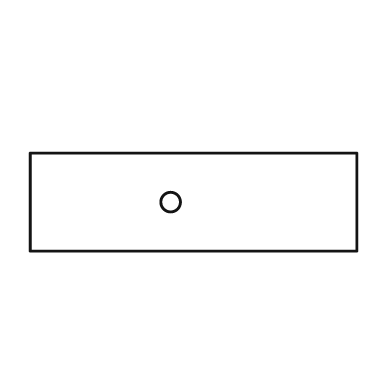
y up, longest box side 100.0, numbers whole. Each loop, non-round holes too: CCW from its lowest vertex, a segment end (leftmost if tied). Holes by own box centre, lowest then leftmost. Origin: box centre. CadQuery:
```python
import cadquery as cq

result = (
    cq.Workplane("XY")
    .moveTo(-50.0, -15.0)
    .lineTo(50.0, -15.0)
    .lineTo(50.0, 15.0)
    .lineTo(-50.0, 15.0)
    .close()
    .moveTo(-7.0, 0.0)
    .circle(3.0)
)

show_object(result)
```